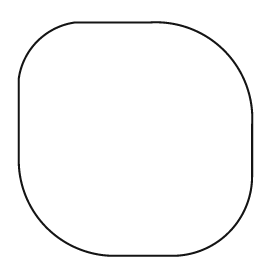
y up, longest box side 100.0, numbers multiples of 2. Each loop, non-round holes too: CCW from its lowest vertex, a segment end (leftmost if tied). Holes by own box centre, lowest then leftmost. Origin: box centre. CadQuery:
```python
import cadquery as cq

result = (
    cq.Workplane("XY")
    .moveTo(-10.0, -50.0)
    .lineTo(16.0, -50.0)
    .threePointArc((40.0, -40.0), (50.0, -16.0))
    .lineTo(50.0, 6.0)
    .threePointArc((38.0, 38.0), (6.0, 50.0))
    .lineTo(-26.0, 50.0)
    .threePointArc((-42.0, 42.0), (-50.0, 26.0))
    .lineTo(-50.0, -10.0)
    .threePointArc((-38.0, -38.0), (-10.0, -50.0))
    .close()
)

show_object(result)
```